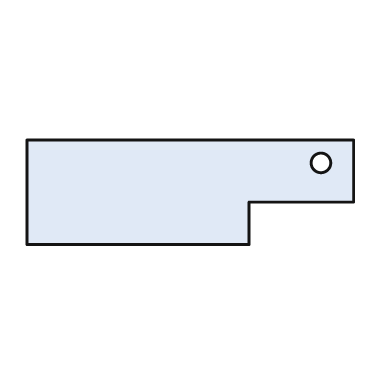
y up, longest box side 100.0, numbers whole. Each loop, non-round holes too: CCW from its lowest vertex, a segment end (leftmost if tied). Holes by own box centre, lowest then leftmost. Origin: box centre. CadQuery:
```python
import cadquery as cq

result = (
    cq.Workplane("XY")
    .moveTo(-50.0, -16.0)
    .lineTo(18.0, -16.0)
    .lineTo(18.0, -3.0)
    .lineTo(50.0, -3.0)
    .lineTo(50.0, 16.0)
    .lineTo(-50.0, 16.0)
    .close()
    .moveTo(40.0, 9.0)
    .circle(3.0)
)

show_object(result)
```